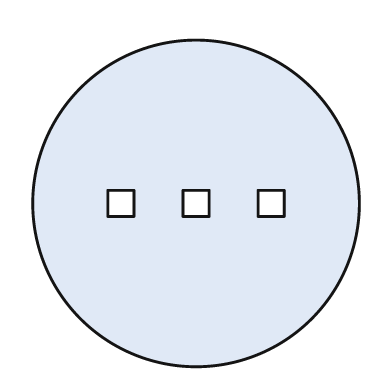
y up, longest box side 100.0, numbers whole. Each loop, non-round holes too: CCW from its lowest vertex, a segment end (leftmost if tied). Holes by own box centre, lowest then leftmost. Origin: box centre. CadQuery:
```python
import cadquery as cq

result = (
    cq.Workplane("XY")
    .moveTo(0.0, 0.0)
    .circle(50.0)
    .moveTo(-27.0, -4.0)
    .lineTo(-19.0, -4.0)
    .lineTo(-19.0, 4.0)
    .lineTo(-27.0, 4.0)
    .close()
    .moveTo(-4.0, -4.0)
    .lineTo(4.0, -4.0)
    .lineTo(4.0, 4.0)
    .lineTo(-4.0, 4.0)
    .close()
    .moveTo(19.0, -4.0)
    .lineTo(27.0, -4.0)
    .lineTo(27.0, 4.0)
    .lineTo(19.0, 4.0)
    .close()
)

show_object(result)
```